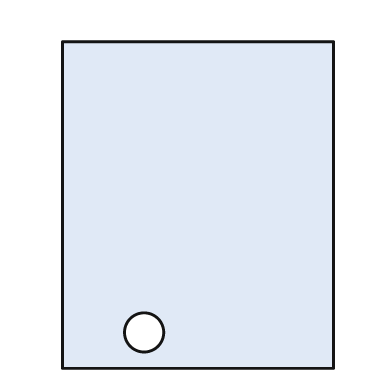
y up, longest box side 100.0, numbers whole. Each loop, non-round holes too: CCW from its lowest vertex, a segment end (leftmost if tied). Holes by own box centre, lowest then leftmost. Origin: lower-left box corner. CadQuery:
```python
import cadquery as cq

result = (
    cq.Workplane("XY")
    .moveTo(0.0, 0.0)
    .lineTo(83.0, 0.0)
    .lineTo(83.0, 100.0)
    .lineTo(0.0, 100.0)
    .close()
    .moveTo(25.0, 11.0)
    .circle(6.0)
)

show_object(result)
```